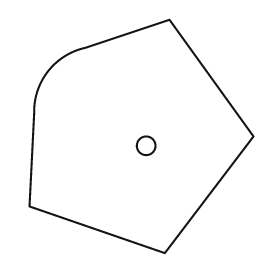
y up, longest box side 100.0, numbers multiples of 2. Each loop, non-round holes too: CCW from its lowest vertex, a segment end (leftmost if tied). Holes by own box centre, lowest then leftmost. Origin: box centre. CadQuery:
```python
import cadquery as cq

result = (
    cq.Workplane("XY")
    .moveTo(10.0, -50.0)
    .lineTo(48.0, 0.0)
    .lineTo(12.0, 50.0)
    .lineTo(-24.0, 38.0)
    .threePointArc((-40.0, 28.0), (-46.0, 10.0))
    .lineTo(-48.0, -30.0)
    .close()
    .moveTo(2.0, -4.0)
    .circle(4.0)
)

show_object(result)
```